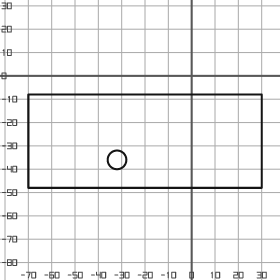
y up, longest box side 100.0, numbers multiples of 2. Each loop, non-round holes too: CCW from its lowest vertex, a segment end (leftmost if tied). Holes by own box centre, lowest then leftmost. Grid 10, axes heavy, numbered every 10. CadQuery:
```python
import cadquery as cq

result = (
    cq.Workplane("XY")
    .moveTo(-70.0, -48.0)
    .lineTo(30.0, -48.0)
    .lineTo(30.0, -8.0)
    .lineTo(-70.0, -8.0)
    .close()
    .moveTo(-32.0, -36.0)
    .circle(4.0)
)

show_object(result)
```